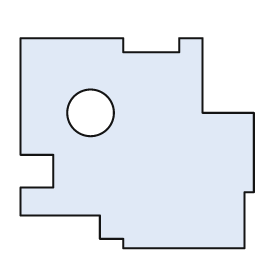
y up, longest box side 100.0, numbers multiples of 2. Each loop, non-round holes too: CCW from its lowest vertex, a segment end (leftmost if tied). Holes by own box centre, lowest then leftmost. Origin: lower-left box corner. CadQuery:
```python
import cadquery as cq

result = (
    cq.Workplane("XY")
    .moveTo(44.0, 0.0)
    .lineTo(96.0, 0.0)
    .lineTo(96.0, 24.0)
    .lineTo(100.0, 24.0)
    .lineTo(100.0, 58.0)
    .lineTo(78.0, 58.0)
    .lineTo(78.0, 90.0)
    .lineTo(68.0, 90.0)
    .lineTo(68.0, 84.0)
    .lineTo(44.0, 84.0)
    .lineTo(44.0, 90.0)
    .lineTo(0.0, 90.0)
    .lineTo(0.0, 40.0)
    .lineTo(14.0, 40.0)
    .lineTo(14.0, 26.0)
    .lineTo(0.0, 26.0)
    .lineTo(0.0, 14.0)
    .lineTo(34.0, 14.0)
    .lineTo(34.0, 4.0)
    .lineTo(44.0, 4.0)
    .close()
    .moveTo(30.0, 58.0)
    .circle(10.0)
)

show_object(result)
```